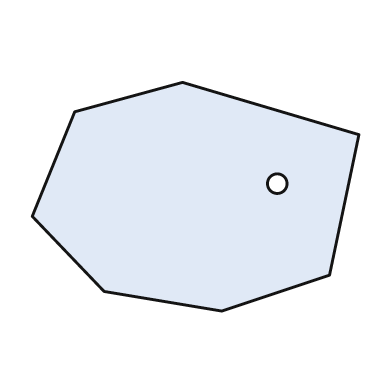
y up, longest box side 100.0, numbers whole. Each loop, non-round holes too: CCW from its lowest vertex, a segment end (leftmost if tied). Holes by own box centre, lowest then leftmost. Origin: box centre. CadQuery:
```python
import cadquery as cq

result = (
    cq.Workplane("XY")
    .moveTo(8.0, -35.0)
    .lineTo(41.0, -24.0)
    .lineTo(50.0, 19.0)
    .lineTo(-4.0, 35.0)
    .lineTo(-37.0, 26.0)
    .lineTo(-50.0, -6.0)
    .lineTo(-28.0, -29.0)
    .close()
    .moveTo(25.0, 4.0)
    .circle(3.0)
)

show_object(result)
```